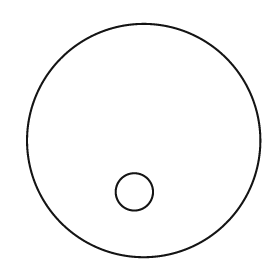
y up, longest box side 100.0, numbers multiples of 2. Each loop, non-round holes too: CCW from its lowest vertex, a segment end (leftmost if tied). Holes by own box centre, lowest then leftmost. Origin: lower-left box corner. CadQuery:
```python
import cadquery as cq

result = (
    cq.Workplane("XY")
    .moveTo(50.0, 50.0)
    .circle(50.0)
    .moveTo(46.0, 28.0)
    .circle(8.0)
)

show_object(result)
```